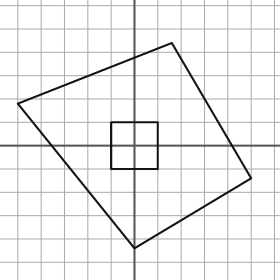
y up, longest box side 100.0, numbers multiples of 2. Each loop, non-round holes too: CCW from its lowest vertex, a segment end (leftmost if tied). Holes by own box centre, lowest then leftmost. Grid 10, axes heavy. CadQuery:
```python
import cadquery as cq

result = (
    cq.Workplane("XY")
    .moveTo(0.0, -44.0)
    .lineTo(50.0, -14.0)
    .lineTo(16.0, 44.0)
    .lineTo(-50.0, 18.0)
    .close()
    .moveTo(-10.0, -10.0)
    .lineTo(10.0, -10.0)
    .lineTo(10.0, 10.0)
    .lineTo(-10.0, 10.0)
    .close()
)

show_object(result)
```